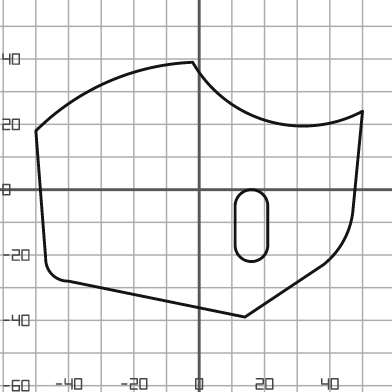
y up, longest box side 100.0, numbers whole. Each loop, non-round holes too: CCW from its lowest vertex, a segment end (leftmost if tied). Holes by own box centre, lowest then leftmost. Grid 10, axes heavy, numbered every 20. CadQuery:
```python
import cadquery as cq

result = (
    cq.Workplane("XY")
    .moveTo(14.0, -39.0)
    .lineTo(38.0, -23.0)
    .threePointArc((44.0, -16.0), (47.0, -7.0))
    .lineTo(50.0, 24.0)
    .threePointArc((21.0, 21.0), (-2.0, 39.0))
    .threePointArc((-28.0, 33.0), (-50.0, 18.0))
    .lineTo(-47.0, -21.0)
    .threePointArc((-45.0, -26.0), (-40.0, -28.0))
    .close()
    .moveTo(11.0, -17.0)
    .threePointArc((16.0, -22.0), (21.0, -17.0))
    .lineTo(21.0, -5.0)
    .threePointArc((16.0, 0.0), (11.0, -5.0))
    .close()
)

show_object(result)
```